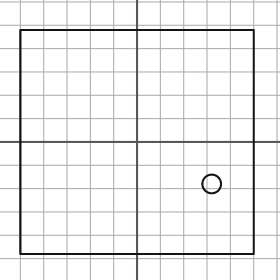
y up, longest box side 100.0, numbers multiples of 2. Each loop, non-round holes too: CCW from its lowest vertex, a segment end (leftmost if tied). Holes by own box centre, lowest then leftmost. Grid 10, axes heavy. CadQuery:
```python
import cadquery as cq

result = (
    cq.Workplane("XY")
    .moveTo(-50.0, -48.0)
    .lineTo(50.0, -48.0)
    .lineTo(50.0, 48.0)
    .lineTo(-50.0, 48.0)
    .close()
    .moveTo(32.0, -18.0)
    .circle(4.0)
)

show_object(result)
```